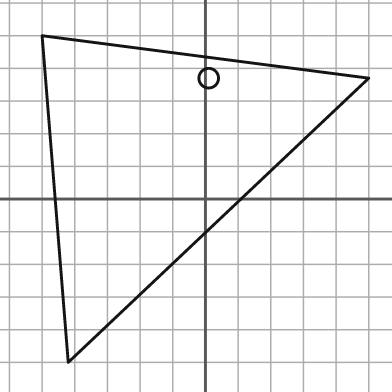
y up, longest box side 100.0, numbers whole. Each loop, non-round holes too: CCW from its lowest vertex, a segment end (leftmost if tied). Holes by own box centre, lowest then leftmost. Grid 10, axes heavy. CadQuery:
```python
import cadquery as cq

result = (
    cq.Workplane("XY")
    .moveTo(-42.0, -50.0)
    .lineTo(50.0, 37.0)
    .lineTo(-50.0, 50.0)
    .close()
    .moveTo(1.0, 37.0)
    .circle(3.0)
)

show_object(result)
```